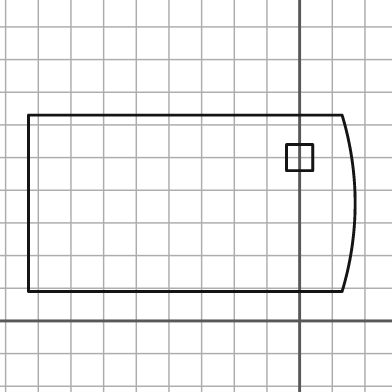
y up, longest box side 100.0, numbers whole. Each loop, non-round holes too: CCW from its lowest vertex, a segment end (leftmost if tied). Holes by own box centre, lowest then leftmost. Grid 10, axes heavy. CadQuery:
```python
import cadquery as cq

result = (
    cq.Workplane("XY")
    .moveTo(-83.0, 9.0)
    .lineTo(13.0, 9.0)
    .threePointArc((17.0, 36.0), (13.0, 63.0))
    .lineTo(-83.0, 63.0)
    .close()
    .moveTo(-4.0, 46.0)
    .lineTo(4.0, 46.0)
    .lineTo(4.0, 54.0)
    .lineTo(-4.0, 54.0)
    .close()
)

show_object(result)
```